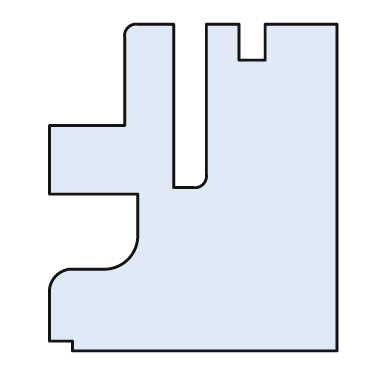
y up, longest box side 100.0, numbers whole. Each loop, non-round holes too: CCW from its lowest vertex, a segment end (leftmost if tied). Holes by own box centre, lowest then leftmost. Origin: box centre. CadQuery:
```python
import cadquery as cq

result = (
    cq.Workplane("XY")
    .moveTo(-37.0, -50.0)
    .lineTo(44.0, -50.0)
    .lineTo(44.0, 50.0)
    .lineTo(22.0, 50.0)
    .lineTo(22.0, 39.0)
    .lineTo(14.0, 39.0)
    .lineTo(14.0, 50.0)
    .lineTo(4.0, 50.0)
    .lineTo(4.0, 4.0)
    .threePointArc((3.0, 1.0), (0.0, 0.0))
    .lineTo(-6.0, 0.0)
    .lineTo(-6.0, 50.0)
    .lineTo(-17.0, 50.0)
    .threePointArc((-20.0, 49.0), (-21.0, 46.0))
    .lineTo(-21.0, 19.0)
    .lineTo(-44.0, 19.0)
    .lineTo(-44.0, -2.0)
    .lineTo(-17.0, -2.0)
    .lineTo(-17.0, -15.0)
    .threePointArc((-20.0, -22.0), (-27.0, -25.0))
    .lineTo(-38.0, -25.0)
    .threePointArc((-42.0, -27.0), (-44.0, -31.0))
    .lineTo(-44.0, -47.0)
    .lineTo(-37.0, -47.0)
    .close()
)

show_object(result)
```